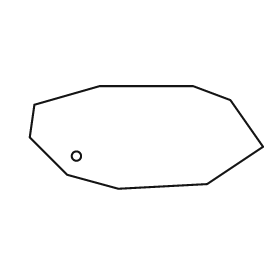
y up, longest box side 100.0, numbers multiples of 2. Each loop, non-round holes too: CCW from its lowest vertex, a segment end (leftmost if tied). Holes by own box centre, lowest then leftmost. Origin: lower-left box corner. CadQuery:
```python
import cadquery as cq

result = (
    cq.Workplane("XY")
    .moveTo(38.0, 0.0)
    .lineTo(76.0, 2.0)
    .lineTo(100.0, 18.0)
    .lineTo(86.0, 38.0)
    .lineTo(70.0, 44.0)
    .lineTo(30.0, 44.0)
    .lineTo(2.0, 36.0)
    .lineTo(0.0, 22.0)
    .lineTo(16.0, 6.0)
    .close()
    .moveTo(20.0, 14.0)
    .circle(2.0)
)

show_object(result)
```